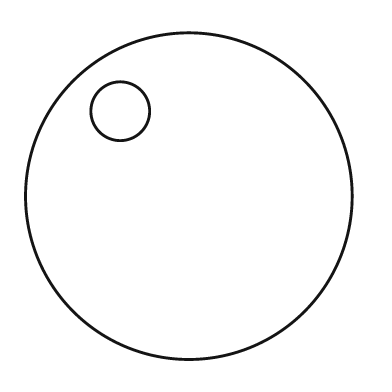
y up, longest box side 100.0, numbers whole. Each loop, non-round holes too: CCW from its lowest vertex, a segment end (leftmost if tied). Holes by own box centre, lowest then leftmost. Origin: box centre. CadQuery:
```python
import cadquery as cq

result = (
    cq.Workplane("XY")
    .moveTo(0.0, 0.0)
    .circle(50.0)
    .moveTo(-21.0, 26.0)
    .circle(9.0)
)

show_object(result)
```